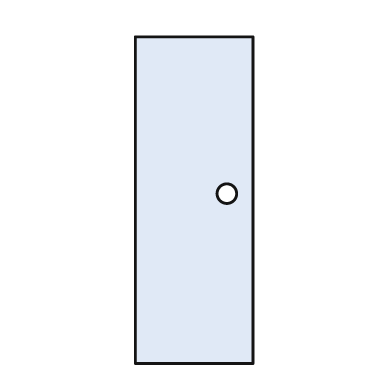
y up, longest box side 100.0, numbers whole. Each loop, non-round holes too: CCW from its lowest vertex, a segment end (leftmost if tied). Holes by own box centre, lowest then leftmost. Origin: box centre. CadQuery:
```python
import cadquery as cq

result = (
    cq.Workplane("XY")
    .moveTo(-18.0, -50.0)
    .lineTo(18.0, -50.0)
    .lineTo(18.0, 50.0)
    .lineTo(-18.0, 50.0)
    .close()
    .moveTo(10.0, 2.0)
    .circle(3.0)
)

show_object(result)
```